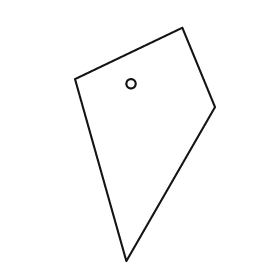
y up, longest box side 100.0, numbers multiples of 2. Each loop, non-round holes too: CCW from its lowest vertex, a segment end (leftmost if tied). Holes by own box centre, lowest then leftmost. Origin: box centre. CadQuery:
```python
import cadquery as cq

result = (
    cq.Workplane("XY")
    .moveTo(-8.0, -50.0)
    .lineTo(30.0, 16.0)
    .lineTo(16.0, 50.0)
    .lineTo(-30.0, 28.0)
    .close()
    .moveTo(-6.0, 26.0)
    .circle(2.0)
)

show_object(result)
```